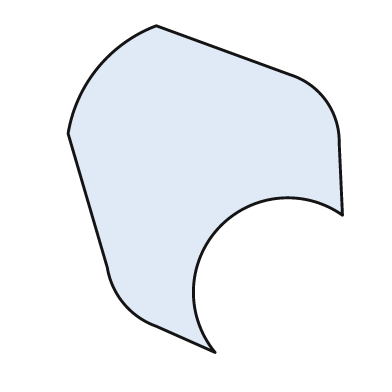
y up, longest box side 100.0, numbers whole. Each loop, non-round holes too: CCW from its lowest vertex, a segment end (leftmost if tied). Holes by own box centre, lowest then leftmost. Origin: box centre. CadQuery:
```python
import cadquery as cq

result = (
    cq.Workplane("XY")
    .moveTo(3.0, -50.0)
    .threePointArc((4.0, -12.0), (42.0, -8.0))
    .lineTo(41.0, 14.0)
    .threePointArc((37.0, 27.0), (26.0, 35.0))
    .lineTo(-15.0, 50.0)
    .threePointArc((-33.0, 37.0), (-42.0, 17.0))
    .lineTo(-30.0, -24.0)
    .threePointArc((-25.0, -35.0), (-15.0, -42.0))
    .close()
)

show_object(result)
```